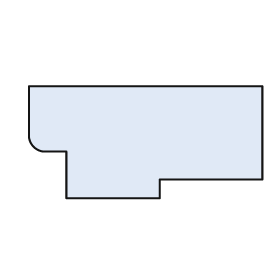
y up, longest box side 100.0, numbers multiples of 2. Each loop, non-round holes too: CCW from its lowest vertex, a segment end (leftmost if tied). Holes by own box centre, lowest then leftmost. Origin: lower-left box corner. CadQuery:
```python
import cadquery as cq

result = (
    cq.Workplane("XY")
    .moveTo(16.0, 0.0)
    .lineTo(56.0, 0.0)
    .lineTo(56.0, 8.0)
    .lineTo(100.0, 8.0)
    .lineTo(100.0, 48.0)
    .lineTo(0.0, 48.0)
    .lineTo(0.0, 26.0)
    .threePointArc((2.0, 22.0), (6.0, 20.0))
    .lineTo(16.0, 20.0)
    .close()
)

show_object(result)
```